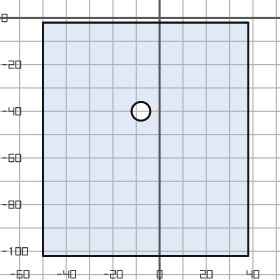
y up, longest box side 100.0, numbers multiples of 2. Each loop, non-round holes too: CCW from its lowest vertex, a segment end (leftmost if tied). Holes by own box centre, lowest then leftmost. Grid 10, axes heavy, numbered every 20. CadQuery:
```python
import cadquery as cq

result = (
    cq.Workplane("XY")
    .moveTo(-50.0, -102.0)
    .lineTo(38.0, -102.0)
    .lineTo(38.0, -2.0)
    .lineTo(-50.0, -2.0)
    .close()
    .moveTo(-8.0, -40.0)
    .circle(4.0)
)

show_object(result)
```